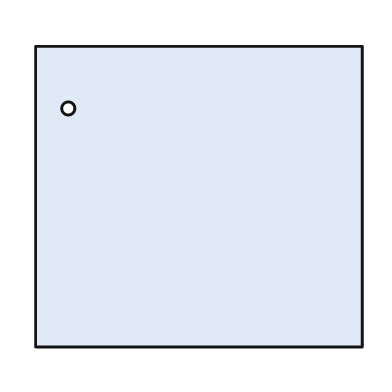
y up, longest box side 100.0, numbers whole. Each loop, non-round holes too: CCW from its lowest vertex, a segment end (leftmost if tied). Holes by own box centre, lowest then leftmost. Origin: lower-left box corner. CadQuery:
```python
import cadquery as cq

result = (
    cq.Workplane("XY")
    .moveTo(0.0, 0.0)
    .lineTo(100.0, 0.0)
    .lineTo(100.0, 92.0)
    .lineTo(0.0, 92.0)
    .close()
    .moveTo(10.0, 73.0)
    .circle(2.0)
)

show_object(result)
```